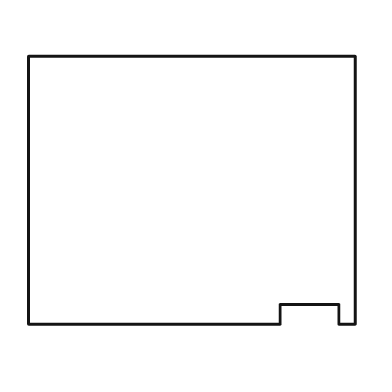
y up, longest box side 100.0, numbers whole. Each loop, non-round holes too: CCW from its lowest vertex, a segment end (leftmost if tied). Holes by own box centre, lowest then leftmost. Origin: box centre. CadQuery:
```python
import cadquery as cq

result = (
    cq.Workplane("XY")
    .moveTo(-50.0, -41.0)
    .lineTo(27.0, -41.0)
    .lineTo(27.0, -35.0)
    .lineTo(45.0, -35.0)
    .lineTo(45.0, -41.0)
    .lineTo(50.0, -41.0)
    .lineTo(50.0, 41.0)
    .lineTo(-50.0, 41.0)
    .close()
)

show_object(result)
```